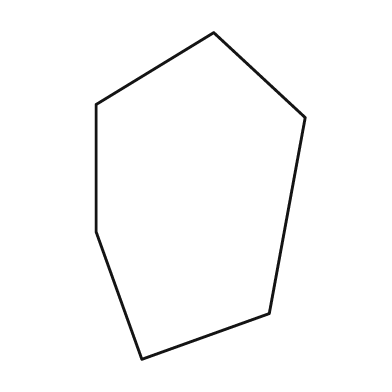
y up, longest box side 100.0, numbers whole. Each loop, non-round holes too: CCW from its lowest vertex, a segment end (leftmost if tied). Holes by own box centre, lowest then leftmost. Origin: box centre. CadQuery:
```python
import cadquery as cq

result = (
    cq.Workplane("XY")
    .moveTo(-18.0, -50.0)
    .lineTo(21.0, -36.0)
    .lineTo(32.0, 24.0)
    .lineTo(4.0, 50.0)
    .lineTo(-32.0, 28.0)
    .lineTo(-32.0, -11.0)
    .close()
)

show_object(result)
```